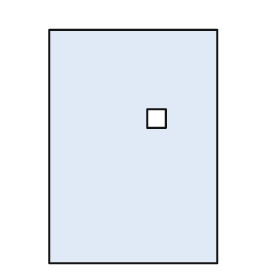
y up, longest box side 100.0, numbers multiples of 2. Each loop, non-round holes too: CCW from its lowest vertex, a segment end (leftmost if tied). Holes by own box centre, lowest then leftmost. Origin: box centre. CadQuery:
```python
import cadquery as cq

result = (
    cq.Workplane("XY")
    .moveTo(-36.0, -50.0)
    .lineTo(36.0, -50.0)
    .lineTo(36.0, 50.0)
    .lineTo(-36.0, 50.0)
    .close()
    .moveTo(6.0, 8.0)
    .lineTo(14.0, 8.0)
    .lineTo(14.0, 16.0)
    .lineTo(6.0, 16.0)
    .close()
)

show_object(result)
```